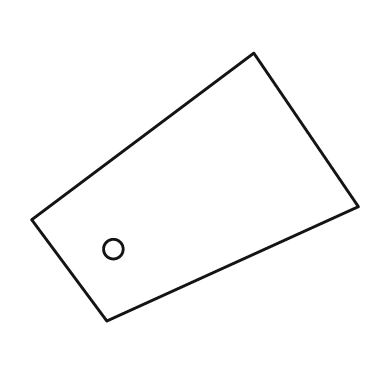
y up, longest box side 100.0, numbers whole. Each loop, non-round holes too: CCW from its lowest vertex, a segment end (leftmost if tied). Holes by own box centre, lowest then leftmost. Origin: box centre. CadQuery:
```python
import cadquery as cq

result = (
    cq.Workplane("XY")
    .moveTo(-27.0, -41.0)
    .lineTo(50.0, -6.0)
    .lineTo(18.0, 41.0)
    .lineTo(-50.0, -10.0)
    .close()
    .moveTo(-25.0, -19.0)
    .circle(3.0)
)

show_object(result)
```